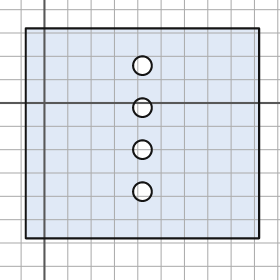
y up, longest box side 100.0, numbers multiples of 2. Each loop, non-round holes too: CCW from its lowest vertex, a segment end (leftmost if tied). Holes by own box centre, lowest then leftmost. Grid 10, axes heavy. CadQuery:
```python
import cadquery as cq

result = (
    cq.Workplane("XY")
    .moveTo(-8.0, -58.0)
    .lineTo(92.0, -58.0)
    .lineTo(92.0, 32.0)
    .lineTo(-8.0, 32.0)
    .close()
    .moveTo(42.0, -38.0)
    .circle(4.0)
    .moveTo(42.0, -20.0)
    .circle(4.0)
    .moveTo(42.0, -2.0)
    .circle(4.0)
    .moveTo(42.0, 16.0)
    .circle(4.0)
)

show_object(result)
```